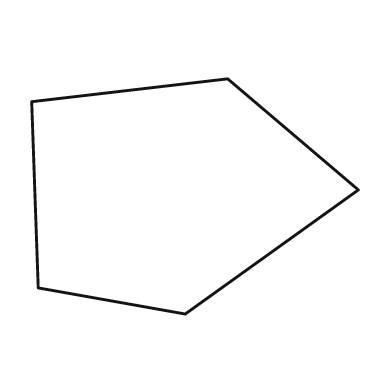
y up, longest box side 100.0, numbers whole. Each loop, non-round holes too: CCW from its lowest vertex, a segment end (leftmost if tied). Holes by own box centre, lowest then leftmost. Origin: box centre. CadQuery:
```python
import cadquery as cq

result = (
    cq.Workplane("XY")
    .moveTo(-3.0, -36.0)
    .lineTo(50.0, 2.0)
    .lineTo(10.0, 36.0)
    .lineTo(-50.0, 29.0)
    .lineTo(-48.0, -28.0)
    .close()
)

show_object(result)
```